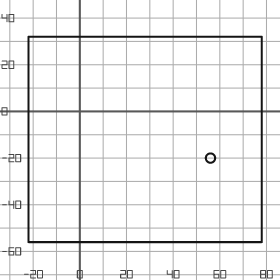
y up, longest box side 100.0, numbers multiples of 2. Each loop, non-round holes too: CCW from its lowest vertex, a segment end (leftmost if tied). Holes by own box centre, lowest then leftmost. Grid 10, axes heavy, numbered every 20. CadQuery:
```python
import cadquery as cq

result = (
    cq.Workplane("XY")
    .moveTo(-22.0, -56.0)
    .lineTo(78.0, -56.0)
    .lineTo(78.0, 32.0)
    .lineTo(-22.0, 32.0)
    .close()
    .moveTo(56.0, -20.0)
    .circle(2.0)
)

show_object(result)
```